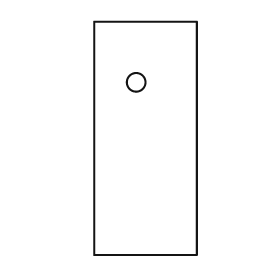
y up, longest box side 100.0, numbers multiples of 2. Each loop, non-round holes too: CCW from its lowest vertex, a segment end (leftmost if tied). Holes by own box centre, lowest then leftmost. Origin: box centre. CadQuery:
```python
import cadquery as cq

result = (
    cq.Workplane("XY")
    .moveTo(-22.0, -50.0)
    .lineTo(22.0, -50.0)
    .lineTo(22.0, 50.0)
    .lineTo(-22.0, 50.0)
    .close()
    .moveTo(-4.0, 24.0)
    .circle(4.0)
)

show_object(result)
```